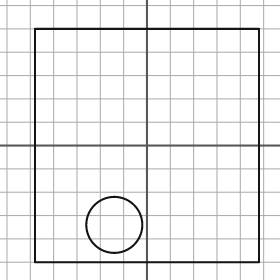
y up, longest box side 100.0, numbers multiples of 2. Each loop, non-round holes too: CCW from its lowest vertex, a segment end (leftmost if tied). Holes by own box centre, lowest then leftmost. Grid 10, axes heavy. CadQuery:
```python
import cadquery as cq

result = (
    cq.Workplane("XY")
    .moveTo(-48.0, -50.0)
    .lineTo(48.0, -50.0)
    .lineTo(48.0, 50.0)
    .lineTo(-48.0, 50.0)
    .close()
    .moveTo(-14.0, -34.0)
    .circle(12.0)
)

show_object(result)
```